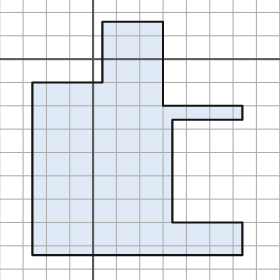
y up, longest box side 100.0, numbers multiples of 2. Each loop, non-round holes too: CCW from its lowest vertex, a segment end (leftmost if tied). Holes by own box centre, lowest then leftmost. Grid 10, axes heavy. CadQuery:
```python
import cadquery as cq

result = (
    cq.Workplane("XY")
    .moveTo(-26.0, -84.0)
    .lineTo(64.0, -84.0)
    .lineTo(64.0, -70.0)
    .lineTo(34.0, -70.0)
    .lineTo(34.0, -26.0)
    .lineTo(64.0, -26.0)
    .lineTo(64.0, -20.0)
    .lineTo(30.0, -20.0)
    .lineTo(30.0, 16.0)
    .lineTo(4.0, 16.0)
    .lineTo(4.0, -10.0)
    .lineTo(-26.0, -10.0)
    .close()
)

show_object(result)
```